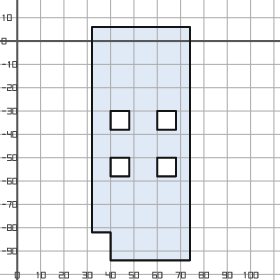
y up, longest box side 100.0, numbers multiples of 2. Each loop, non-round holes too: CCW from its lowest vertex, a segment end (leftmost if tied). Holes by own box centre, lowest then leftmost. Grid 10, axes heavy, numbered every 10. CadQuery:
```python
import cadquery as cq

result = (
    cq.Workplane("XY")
    .moveTo(40.0, -94.0)
    .lineTo(74.0, -94.0)
    .lineTo(74.0, 6.0)
    .lineTo(32.0, 6.0)
    .lineTo(32.0, -82.0)
    .lineTo(40.0, -82.0)
    .close()
    .moveTo(40.0, -58.0)
    .lineTo(48.0, -58.0)
    .lineTo(48.0, -50.0)
    .lineTo(40.0, -50.0)
    .close()
    .moveTo(60.0, -58.0)
    .lineTo(68.0, -58.0)
    .lineTo(68.0, -50.0)
    .lineTo(60.0, -50.0)
    .close()
    .moveTo(40.0, -38.0)
    .lineTo(48.0, -38.0)
    .lineTo(48.0, -30.0)
    .lineTo(40.0, -30.0)
    .close()
    .moveTo(60.0, -38.0)
    .lineTo(68.0, -38.0)
    .lineTo(68.0, -30.0)
    .lineTo(60.0, -30.0)
    .close()
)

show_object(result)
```